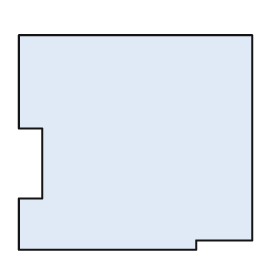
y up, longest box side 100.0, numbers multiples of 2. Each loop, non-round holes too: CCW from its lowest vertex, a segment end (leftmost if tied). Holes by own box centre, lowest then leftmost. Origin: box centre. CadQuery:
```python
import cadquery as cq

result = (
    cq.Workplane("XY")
    .moveTo(-50.0, -46.0)
    .lineTo(26.0, -46.0)
    .lineTo(26.0, -42.0)
    .lineTo(50.0, -42.0)
    .lineTo(50.0, 46.0)
    .lineTo(-50.0, 46.0)
    .lineTo(-50.0, 6.0)
    .lineTo(-40.0, 6.0)
    .lineTo(-40.0, -24.0)
    .lineTo(-50.0, -24.0)
    .close()
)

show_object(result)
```